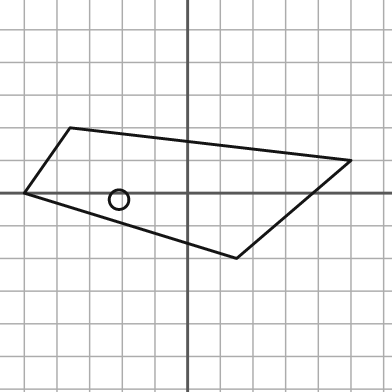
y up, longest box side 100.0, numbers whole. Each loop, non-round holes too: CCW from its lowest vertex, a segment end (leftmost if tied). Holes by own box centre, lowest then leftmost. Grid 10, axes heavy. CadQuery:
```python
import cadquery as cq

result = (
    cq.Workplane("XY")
    .moveTo(15.0, -20.0)
    .lineTo(50.0, 10.0)
    .lineTo(-36.0, 20.0)
    .lineTo(-50.0, 0.0)
    .close()
    .moveTo(-21.0, -2.0)
    .circle(3.0)
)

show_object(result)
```